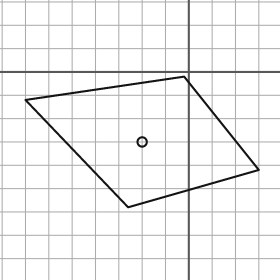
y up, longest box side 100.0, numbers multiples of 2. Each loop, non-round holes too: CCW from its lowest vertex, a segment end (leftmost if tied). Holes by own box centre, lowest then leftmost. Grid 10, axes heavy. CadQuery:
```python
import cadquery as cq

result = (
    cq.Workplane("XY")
    .moveTo(-26.0, -58.0)
    .lineTo(30.0, -42.0)
    .lineTo(-2.0, -2.0)
    .lineTo(-70.0, -12.0)
    .close()
    .moveTo(-20.0, -30.0)
    .circle(2.0)
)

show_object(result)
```